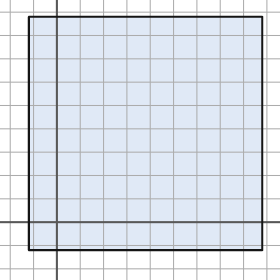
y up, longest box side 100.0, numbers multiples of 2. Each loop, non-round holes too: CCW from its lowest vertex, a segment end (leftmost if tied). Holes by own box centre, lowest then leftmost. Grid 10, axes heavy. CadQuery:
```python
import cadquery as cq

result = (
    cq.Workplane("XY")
    .moveTo(-12.0, -12.0)
    .lineTo(88.0, -12.0)
    .lineTo(88.0, 88.0)
    .lineTo(-12.0, 88.0)
    .close()
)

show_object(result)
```